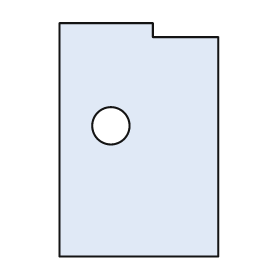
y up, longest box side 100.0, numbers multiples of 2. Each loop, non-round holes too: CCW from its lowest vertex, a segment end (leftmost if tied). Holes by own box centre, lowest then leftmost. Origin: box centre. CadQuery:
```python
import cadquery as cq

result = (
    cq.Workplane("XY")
    .moveTo(-34.0, -50.0)
    .lineTo(34.0, -50.0)
    .lineTo(34.0, 44.0)
    .lineTo(6.0, 44.0)
    .lineTo(6.0, 50.0)
    .lineTo(-34.0, 50.0)
    .close()
    .moveTo(-12.0, 6.0)
    .circle(8.0)
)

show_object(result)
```